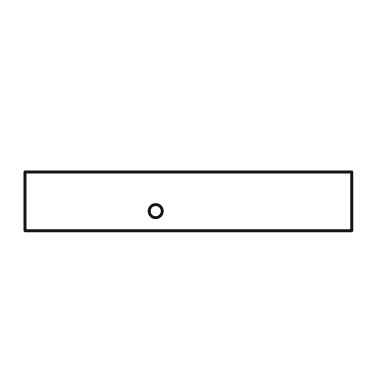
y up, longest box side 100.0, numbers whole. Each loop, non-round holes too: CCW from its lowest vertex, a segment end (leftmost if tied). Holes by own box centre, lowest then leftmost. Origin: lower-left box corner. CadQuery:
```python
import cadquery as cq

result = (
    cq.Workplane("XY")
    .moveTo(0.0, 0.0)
    .lineTo(100.0, 0.0)
    .lineTo(100.0, 18.0)
    .lineTo(0.0, 18.0)
    .close()
    .moveTo(40.0, 6.0)
    .circle(2.0)
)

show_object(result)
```